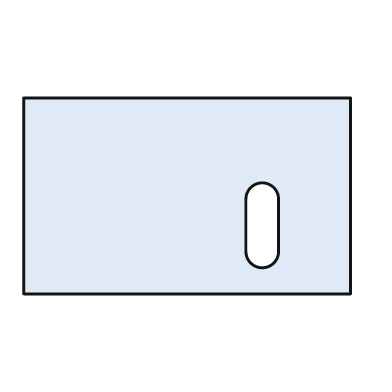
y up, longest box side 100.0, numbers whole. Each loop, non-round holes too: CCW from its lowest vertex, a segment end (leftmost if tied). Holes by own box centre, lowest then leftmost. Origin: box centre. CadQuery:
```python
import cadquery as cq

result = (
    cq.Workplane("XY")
    .moveTo(-50.0, -30.0)
    .lineTo(50.0, -30.0)
    .lineTo(50.0, 30.0)
    .lineTo(-50.0, 30.0)
    .close()
    .moveTo(18.0, -17.0)
    .threePointArc((23.0, -22.0), (28.0, -17.0))
    .lineTo(28.0, -1.0)
    .threePointArc((23.0, 4.0), (18.0, -1.0))
    .close()
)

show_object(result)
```